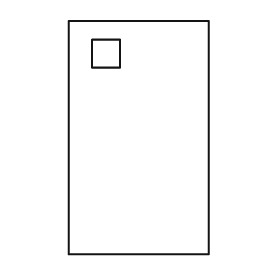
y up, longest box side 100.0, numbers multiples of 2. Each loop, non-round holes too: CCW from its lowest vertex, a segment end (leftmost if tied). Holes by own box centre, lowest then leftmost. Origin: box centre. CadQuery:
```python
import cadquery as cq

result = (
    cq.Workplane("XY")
    .moveTo(-30.0, -50.0)
    .lineTo(30.0, -50.0)
    .lineTo(30.0, 50.0)
    .lineTo(-30.0, 50.0)
    .close()
    .moveTo(-20.0, 30.0)
    .lineTo(-8.0, 30.0)
    .lineTo(-8.0, 42.0)
    .lineTo(-20.0, 42.0)
    .close()
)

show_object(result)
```